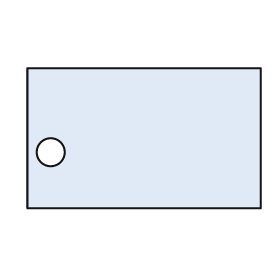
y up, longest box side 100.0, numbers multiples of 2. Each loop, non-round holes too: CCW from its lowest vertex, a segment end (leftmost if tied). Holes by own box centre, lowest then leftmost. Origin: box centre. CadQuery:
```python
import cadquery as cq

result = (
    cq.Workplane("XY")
    .moveTo(-50.0, -30.0)
    .lineTo(50.0, -30.0)
    .lineTo(50.0, 30.0)
    .lineTo(-50.0, 30.0)
    .close()
    .moveTo(-40.0, -6.0)
    .circle(6.0)
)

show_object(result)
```